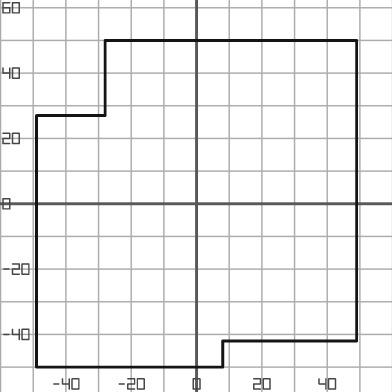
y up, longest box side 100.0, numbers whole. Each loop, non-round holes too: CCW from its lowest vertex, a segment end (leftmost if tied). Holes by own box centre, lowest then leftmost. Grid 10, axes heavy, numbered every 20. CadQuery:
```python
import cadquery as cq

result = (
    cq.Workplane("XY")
    .moveTo(-49.0, -50.0)
    .lineTo(8.0, -50.0)
    .lineTo(8.0, -42.0)
    .lineTo(49.0, -42.0)
    .lineTo(49.0, 50.0)
    .lineTo(-28.0, 50.0)
    .lineTo(-28.0, 27.0)
    .lineTo(-49.0, 27.0)
    .close()
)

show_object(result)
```